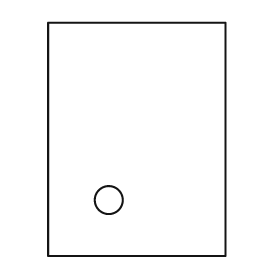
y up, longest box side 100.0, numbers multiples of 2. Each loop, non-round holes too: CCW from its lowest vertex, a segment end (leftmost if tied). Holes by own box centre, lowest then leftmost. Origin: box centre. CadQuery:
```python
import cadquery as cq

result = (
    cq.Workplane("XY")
    .moveTo(-38.0, -50.0)
    .lineTo(38.0, -50.0)
    .lineTo(38.0, 50.0)
    .lineTo(-38.0, 50.0)
    .close()
    .moveTo(-12.0, -26.0)
    .circle(6.0)
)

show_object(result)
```